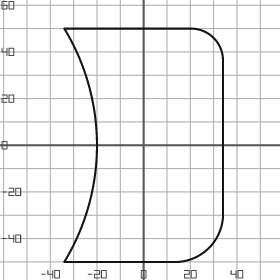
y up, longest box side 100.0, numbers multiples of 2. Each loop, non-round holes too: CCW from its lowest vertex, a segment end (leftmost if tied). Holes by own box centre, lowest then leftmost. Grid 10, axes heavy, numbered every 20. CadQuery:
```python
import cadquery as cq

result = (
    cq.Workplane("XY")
    .moveTo(-34.0, -50.0)
    .lineTo(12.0, -50.0)
    .threePointArc((28.0, -44.0), (34.0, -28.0))
    .lineTo(34.0, 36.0)
    .threePointArc((30.0, 46.0), (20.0, 50.0))
    .lineTo(-34.0, 50.0)
    .threePointArc((-20.0, 0.0), (-34.0, -50.0))
    .close()
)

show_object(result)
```